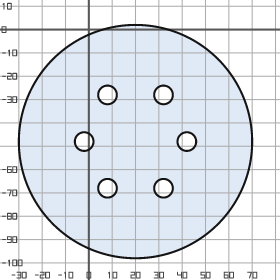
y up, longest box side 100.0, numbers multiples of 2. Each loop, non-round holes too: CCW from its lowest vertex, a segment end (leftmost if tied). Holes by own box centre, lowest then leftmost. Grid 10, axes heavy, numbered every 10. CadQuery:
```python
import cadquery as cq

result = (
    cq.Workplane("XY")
    .moveTo(20.0, -48.0)
    .circle(50.0)
    .moveTo(8.0, -68.0)
    .circle(4.0)
    .moveTo(32.0, -68.0)
    .circle(4.0)
    .moveTo(-2.0, -48.0)
    .circle(4.0)
    .moveTo(42.0, -48.0)
    .circle(4.0)
    .moveTo(8.0, -28.0)
    .circle(4.0)
    .moveTo(32.0, -28.0)
    .circle(4.0)
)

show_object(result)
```